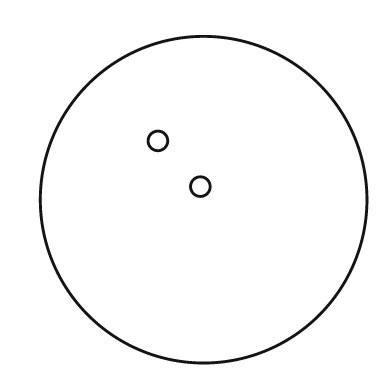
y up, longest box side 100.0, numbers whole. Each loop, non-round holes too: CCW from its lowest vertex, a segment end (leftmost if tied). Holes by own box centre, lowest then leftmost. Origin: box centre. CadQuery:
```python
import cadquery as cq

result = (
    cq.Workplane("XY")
    .moveTo(0.0, 0.0)
    .circle(50.0)
    .moveTo(-1.0, 4.0)
    .circle(3.0)
    .moveTo(-14.0, 18.0)
    .circle(3.0)
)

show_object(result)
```